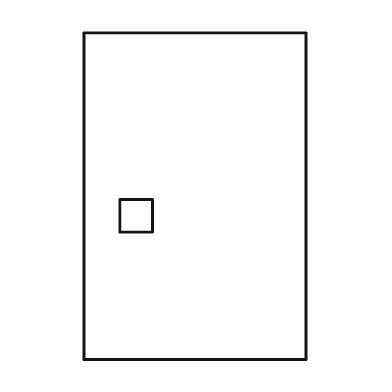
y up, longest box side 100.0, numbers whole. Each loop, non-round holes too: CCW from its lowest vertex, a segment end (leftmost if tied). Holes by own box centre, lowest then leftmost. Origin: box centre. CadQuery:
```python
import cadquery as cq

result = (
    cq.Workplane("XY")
    .moveTo(-34.0, -50.0)
    .lineTo(34.0, -50.0)
    .lineTo(34.0, 50.0)
    .lineTo(-34.0, 50.0)
    .close()
    .moveTo(-23.0, -11.0)
    .lineTo(-13.0, -11.0)
    .lineTo(-13.0, -1.0)
    .lineTo(-23.0, -1.0)
    .close()
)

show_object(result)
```